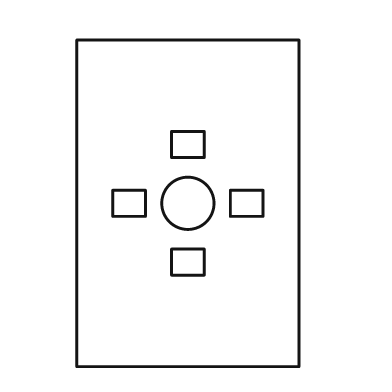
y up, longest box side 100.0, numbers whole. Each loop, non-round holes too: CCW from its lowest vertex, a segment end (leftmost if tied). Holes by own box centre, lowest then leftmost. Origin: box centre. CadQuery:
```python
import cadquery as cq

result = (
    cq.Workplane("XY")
    .moveTo(-34.0, -50.0)
    .lineTo(34.0, -50.0)
    .lineTo(34.0, 50.0)
    .lineTo(-34.0, 50.0)
    .close()
    .moveTo(-5.0, -22.0)
    .lineTo(5.0, -22.0)
    .lineTo(5.0, -14.0)
    .lineTo(-5.0, -14.0)
    .close()
    .moveTo(-23.0, -4.0)
    .lineTo(-13.0, -4.0)
    .lineTo(-13.0, 4.0)
    .lineTo(-23.0, 4.0)
    .close()
    .moveTo(0.0, 0.0)
    .circle(8.0)
    .moveTo(13.0, -4.0)
    .lineTo(23.0, -4.0)
    .lineTo(23.0, 4.0)
    .lineTo(13.0, 4.0)
    .close()
    .moveTo(-5.0, 14.0)
    .lineTo(5.0, 14.0)
    .lineTo(5.0, 22.0)
    .lineTo(-5.0, 22.0)
    .close()
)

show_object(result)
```